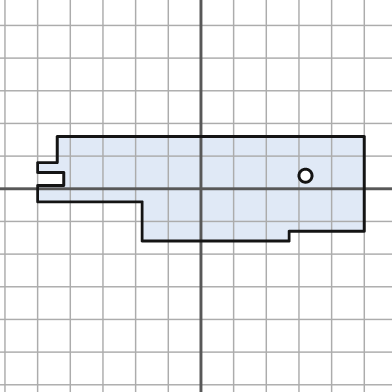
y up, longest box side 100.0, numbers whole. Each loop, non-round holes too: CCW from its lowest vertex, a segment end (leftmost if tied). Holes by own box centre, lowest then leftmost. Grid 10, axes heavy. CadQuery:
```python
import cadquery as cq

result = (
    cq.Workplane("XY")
    .moveTo(-18.0, -16.0)
    .lineTo(27.0, -16.0)
    .lineTo(27.0, -13.0)
    .lineTo(50.0, -13.0)
    .lineTo(50.0, 16.0)
    .lineTo(-44.0, 16.0)
    .lineTo(-44.0, 8.0)
    .lineTo(-50.0, 8.0)
    .lineTo(-50.0, 5.0)
    .lineTo(-42.0, 5.0)
    .lineTo(-42.0, 1.0)
    .lineTo(-50.0, 1.0)
    .lineTo(-50.0, -4.0)
    .lineTo(-18.0, -4.0)
    .close()
    .moveTo(32.0, 4.0)
    .circle(2.0)
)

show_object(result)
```